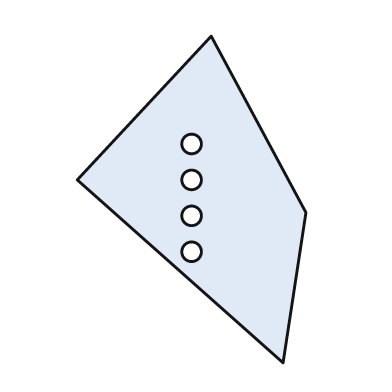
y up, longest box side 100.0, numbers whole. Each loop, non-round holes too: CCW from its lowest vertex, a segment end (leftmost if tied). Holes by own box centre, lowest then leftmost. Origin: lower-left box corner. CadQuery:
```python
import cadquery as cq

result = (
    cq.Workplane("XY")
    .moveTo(63.0, 0.0)
    .lineTo(70.0, 46.0)
    .lineTo(41.0, 100.0)
    .lineTo(0.0, 56.0)
    .close()
    .moveTo(35.0, 34.0)
    .circle(3.0)
    .moveTo(35.0, 45.0)
    .circle(3.0)
    .moveTo(35.0, 56.0)
    .circle(3.0)
    .moveTo(35.0, 67.0)
    .circle(3.0)
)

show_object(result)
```